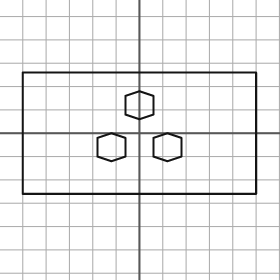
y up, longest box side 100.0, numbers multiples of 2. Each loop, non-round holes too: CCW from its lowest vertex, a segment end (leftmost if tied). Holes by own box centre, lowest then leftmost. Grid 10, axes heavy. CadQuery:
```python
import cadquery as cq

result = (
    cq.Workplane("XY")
    .moveTo(-50.0, -26.0)
    .lineTo(50.0, -26.0)
    .lineTo(50.0, 26.0)
    .lineTo(-50.0, 26.0)
    .close()
    .moveTo(-12.0, -12.0)
    .lineTo(-6.0, -10.0)
    .lineTo(-6.0, -2.0)
    .lineTo(-12.0, 0.0)
    .lineTo(-18.0, -2.0)
    .lineTo(-18.0, -10.0)
    .close()
    .moveTo(12.0, -12.0)
    .lineTo(18.0, -10.0)
    .lineTo(18.0, -2.0)
    .lineTo(12.0, 0.0)
    .lineTo(6.0, -2.0)
    .lineTo(6.0, -10.0)
    .close()
    .moveTo(0.0, 6.0)
    .lineTo(6.0, 8.0)
    .lineTo(6.0, 16.0)
    .lineTo(0.0, 18.0)
    .lineTo(-6.0, 16.0)
    .lineTo(-6.0, 8.0)
    .close()
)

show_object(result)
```